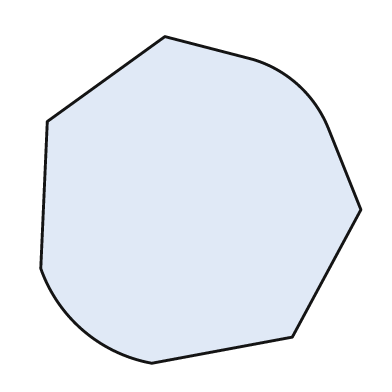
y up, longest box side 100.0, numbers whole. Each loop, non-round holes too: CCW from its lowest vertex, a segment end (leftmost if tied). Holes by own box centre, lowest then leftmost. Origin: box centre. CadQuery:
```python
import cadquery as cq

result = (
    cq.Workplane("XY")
    .moveTo(-15.0, -50.0)
    .lineTo(28.0, -42.0)
    .lineTo(49.0, -3.0)
    .lineTo(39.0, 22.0)
    .threePointArc((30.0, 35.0), (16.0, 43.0))
    .lineTo(-11.0, 50.0)
    .lineTo(-47.0, 24.0)
    .lineTo(-49.0, -21.0)
    .threePointArc((-36.0, -40.0), (-15.0, -50.0))
    .close()
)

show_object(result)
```